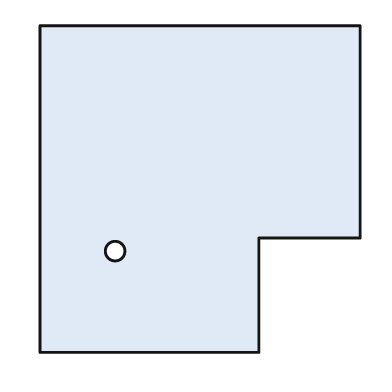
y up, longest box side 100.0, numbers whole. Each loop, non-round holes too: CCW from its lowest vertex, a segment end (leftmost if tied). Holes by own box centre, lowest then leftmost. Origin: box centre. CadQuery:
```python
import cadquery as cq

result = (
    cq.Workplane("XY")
    .moveTo(-49.0, -50.0)
    .lineTo(18.0, -50.0)
    .lineTo(18.0, -15.0)
    .lineTo(49.0, -15.0)
    .lineTo(49.0, 50.0)
    .lineTo(-49.0, 50.0)
    .close()
    .moveTo(-26.0, -19.0)
    .circle(3.0)
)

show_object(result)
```